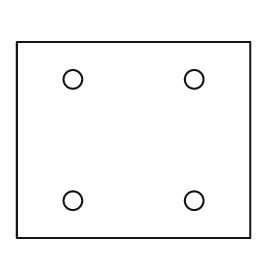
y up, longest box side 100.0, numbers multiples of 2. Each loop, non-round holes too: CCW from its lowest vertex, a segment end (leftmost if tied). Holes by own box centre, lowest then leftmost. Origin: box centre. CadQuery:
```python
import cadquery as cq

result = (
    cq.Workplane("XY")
    .moveTo(-50.0, -42.0)
    .lineTo(50.0, -42.0)
    .lineTo(50.0, 42.0)
    .lineTo(-50.0, 42.0)
    .close()
    .moveTo(-26.0, -26.0)
    .circle(4.0)
    .moveTo(26.0, -26.0)
    .circle(4.0)
    .moveTo(-26.0, 26.0)
    .circle(4.0)
    .moveTo(26.0, 26.0)
    .circle(4.0)
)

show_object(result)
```